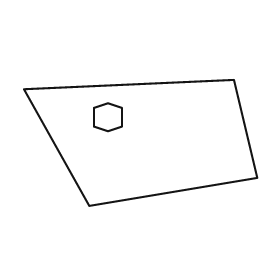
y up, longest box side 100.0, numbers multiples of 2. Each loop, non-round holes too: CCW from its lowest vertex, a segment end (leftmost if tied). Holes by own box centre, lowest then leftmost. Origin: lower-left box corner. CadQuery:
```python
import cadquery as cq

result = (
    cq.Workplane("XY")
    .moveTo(28.0, 0.0)
    .lineTo(100.0, 12.0)
    .lineTo(90.0, 54.0)
    .lineTo(0.0, 50.0)
    .close()
    .moveTo(36.0, 32.0)
    .lineTo(42.0, 34.0)
    .lineTo(42.0, 42.0)
    .lineTo(36.0, 44.0)
    .lineTo(30.0, 42.0)
    .lineTo(30.0, 34.0)
    .close()
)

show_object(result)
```